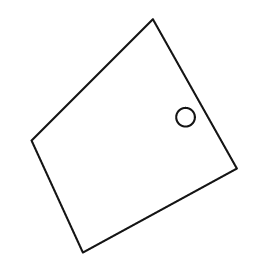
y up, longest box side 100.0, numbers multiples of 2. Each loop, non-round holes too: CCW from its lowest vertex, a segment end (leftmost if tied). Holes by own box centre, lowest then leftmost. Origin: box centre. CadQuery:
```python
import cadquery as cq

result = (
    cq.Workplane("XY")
    .moveTo(-22.0, -50.0)
    .lineTo(44.0, -14.0)
    .lineTo(8.0, 50.0)
    .lineTo(-44.0, -2.0)
    .close()
    .moveTo(22.0, 8.0)
    .circle(4.0)
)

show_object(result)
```